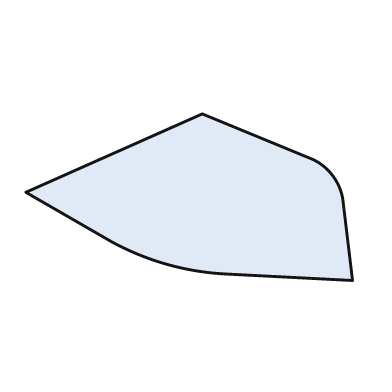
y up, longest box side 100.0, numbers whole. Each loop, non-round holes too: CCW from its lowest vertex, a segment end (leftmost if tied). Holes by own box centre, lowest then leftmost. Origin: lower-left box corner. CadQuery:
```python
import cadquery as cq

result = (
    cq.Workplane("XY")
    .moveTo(100.0, 0.0)
    .lineTo(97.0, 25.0)
    .threePointArc((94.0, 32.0), (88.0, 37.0))
    .lineTo(54.0, 51.0)
    .lineTo(0.0, 27.0)
    .lineTo(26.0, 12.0)
    .threePointArc((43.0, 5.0), (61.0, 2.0))
    .close()
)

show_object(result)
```